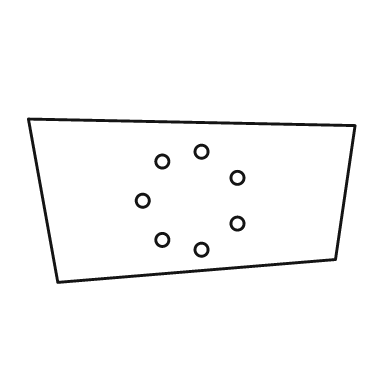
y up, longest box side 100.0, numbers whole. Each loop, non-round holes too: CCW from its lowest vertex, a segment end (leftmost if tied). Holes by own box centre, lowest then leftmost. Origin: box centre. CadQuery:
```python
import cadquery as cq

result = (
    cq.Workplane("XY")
    .moveTo(-41.0, -25.0)
    .lineTo(44.0, -18.0)
    .lineTo(50.0, 23.0)
    .lineTo(-50.0, 25.0)
    .close()
    .moveTo(3.0, -15.0)
    .circle(2.0)
    .moveTo(-9.0, -12.0)
    .circle(2.0)
    .moveTo(14.0, -7.0)
    .circle(2.0)
    .moveTo(-15.0, 0.0)
    .circle(2.0)
    .moveTo(14.0, 7.0)
    .circle(2.0)
    .moveTo(-9.0, 12.0)
    .circle(2.0)
    .moveTo(3.0, 15.0)
    .circle(2.0)
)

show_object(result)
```